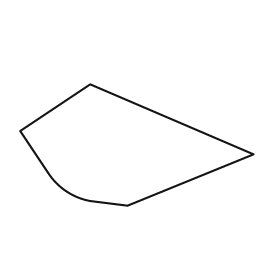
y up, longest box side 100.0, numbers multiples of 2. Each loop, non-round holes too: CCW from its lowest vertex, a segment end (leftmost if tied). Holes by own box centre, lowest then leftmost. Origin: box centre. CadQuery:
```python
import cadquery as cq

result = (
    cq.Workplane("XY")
    .moveTo(-4.0, -26.0)
    .lineTo(50.0, -4.0)
    .lineTo(-20.0, 26.0)
    .lineTo(-50.0, 6.0)
    .lineTo(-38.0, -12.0)
    .threePointArc((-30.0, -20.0), (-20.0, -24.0))
    .close()
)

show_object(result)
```